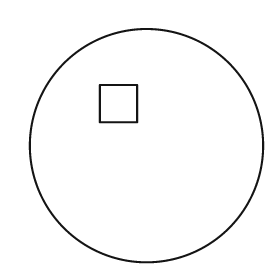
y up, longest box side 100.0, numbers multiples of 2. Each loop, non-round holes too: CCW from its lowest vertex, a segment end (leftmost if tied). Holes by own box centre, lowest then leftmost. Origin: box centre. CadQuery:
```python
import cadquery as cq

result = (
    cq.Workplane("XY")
    .moveTo(0.0, 0.0)
    .circle(50.0)
    .moveTo(-20.0, 10.0)
    .lineTo(-4.0, 10.0)
    .lineTo(-4.0, 26.0)
    .lineTo(-20.0, 26.0)
    .close()
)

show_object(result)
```